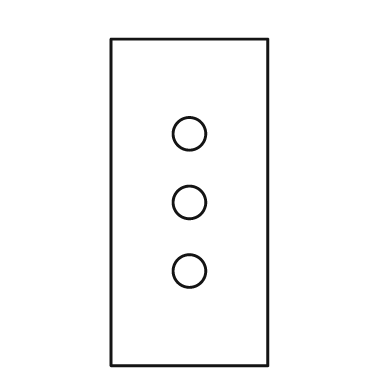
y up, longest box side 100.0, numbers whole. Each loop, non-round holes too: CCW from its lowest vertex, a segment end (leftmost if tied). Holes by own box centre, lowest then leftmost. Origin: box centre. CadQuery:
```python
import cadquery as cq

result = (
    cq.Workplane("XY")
    .moveTo(-24.0, -50.0)
    .lineTo(24.0, -50.0)
    .lineTo(24.0, 50.0)
    .lineTo(-24.0, 50.0)
    .close()
    .moveTo(0.0, -21.0)
    .circle(5.0)
    .moveTo(0.0, 0.0)
    .circle(5.0)
    .moveTo(0.0, 21.0)
    .circle(5.0)
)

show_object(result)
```